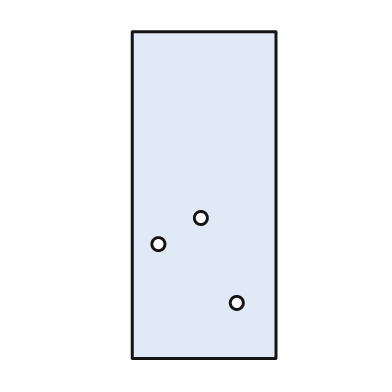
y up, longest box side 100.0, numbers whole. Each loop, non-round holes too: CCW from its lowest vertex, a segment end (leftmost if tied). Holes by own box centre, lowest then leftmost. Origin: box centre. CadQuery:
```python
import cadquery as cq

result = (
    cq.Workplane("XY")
    .moveTo(-22.0, -50.0)
    .lineTo(22.0, -50.0)
    .lineTo(22.0, 50.0)
    .lineTo(-22.0, 50.0)
    .close()
    .moveTo(10.0, -33.0)
    .circle(2.0)
    .moveTo(-14.0, -15.0)
    .circle(2.0)
    .moveTo(-1.0, -7.0)
    .circle(2.0)
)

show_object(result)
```